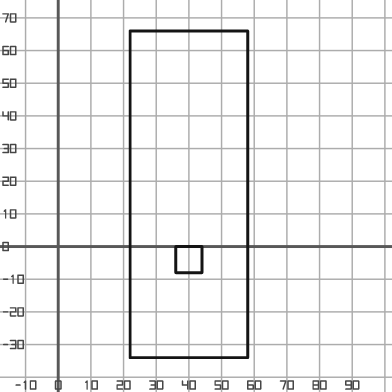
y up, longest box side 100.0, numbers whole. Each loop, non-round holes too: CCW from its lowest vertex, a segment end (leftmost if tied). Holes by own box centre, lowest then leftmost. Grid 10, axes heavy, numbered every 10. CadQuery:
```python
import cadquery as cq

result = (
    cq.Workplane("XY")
    .moveTo(22.0, -34.0)
    .lineTo(58.0, -34.0)
    .lineTo(58.0, 66.0)
    .lineTo(22.0, 66.0)
    .close()
    .moveTo(36.0, -8.0)
    .lineTo(44.0, -8.0)
    .lineTo(44.0, 0.0)
    .lineTo(36.0, 0.0)
    .close()
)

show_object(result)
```